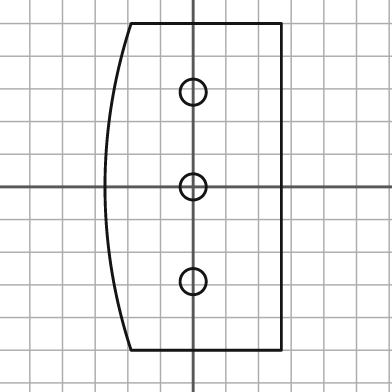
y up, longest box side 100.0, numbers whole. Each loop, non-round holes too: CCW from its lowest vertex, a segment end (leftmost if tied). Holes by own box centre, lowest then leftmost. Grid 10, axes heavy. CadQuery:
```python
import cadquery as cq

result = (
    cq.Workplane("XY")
    .moveTo(-19.0, -50.0)
    .lineTo(27.0, -50.0)
    .lineTo(27.0, 50.0)
    .lineTo(-19.0, 50.0)
    .threePointArc((-27.0, 0.0), (-19.0, -50.0))
    .close()
    .moveTo(0.0, -29.0)
    .circle(4.0)
    .moveTo(0.0, 0.0)
    .circle(4.0)
    .moveTo(0.0, 29.0)
    .circle(4.0)
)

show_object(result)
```